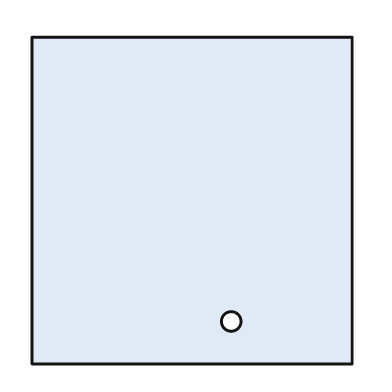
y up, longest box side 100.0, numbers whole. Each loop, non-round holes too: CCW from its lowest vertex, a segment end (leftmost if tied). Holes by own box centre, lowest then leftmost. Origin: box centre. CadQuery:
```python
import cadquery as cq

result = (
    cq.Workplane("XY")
    .moveTo(-49.0, -50.0)
    .lineTo(49.0, -50.0)
    .lineTo(49.0, 50.0)
    .lineTo(-49.0, 50.0)
    .close()
    .moveTo(12.0, -37.0)
    .circle(3.0)
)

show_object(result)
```